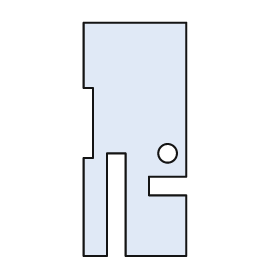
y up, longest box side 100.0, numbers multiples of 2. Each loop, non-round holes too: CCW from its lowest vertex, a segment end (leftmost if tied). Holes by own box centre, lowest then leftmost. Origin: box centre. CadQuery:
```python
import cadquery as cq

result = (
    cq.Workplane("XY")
    .moveTo(-22.0, -50.0)
    .lineTo(-12.0, -50.0)
    .lineTo(-12.0, -6.0)
    .lineTo(-4.0, -6.0)
    .lineTo(-4.0, -50.0)
    .lineTo(22.0, -50.0)
    .lineTo(22.0, -24.0)
    .lineTo(6.0, -24.0)
    .lineTo(6.0, -16.0)
    .lineTo(22.0, -16.0)
    .lineTo(22.0, 50.0)
    .lineTo(-22.0, 50.0)
    .lineTo(-22.0, 22.0)
    .lineTo(-18.0, 22.0)
    .lineTo(-18.0, -8.0)
    .lineTo(-22.0, -8.0)
    .close()
    .moveTo(14.0, -6.0)
    .circle(4.0)
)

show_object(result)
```